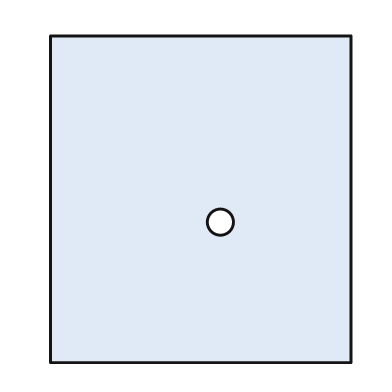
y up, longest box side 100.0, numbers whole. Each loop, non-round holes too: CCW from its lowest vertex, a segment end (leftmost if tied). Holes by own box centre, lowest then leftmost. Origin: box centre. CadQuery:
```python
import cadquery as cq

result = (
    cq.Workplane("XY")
    .moveTo(-46.0, -50.0)
    .lineTo(46.0, -50.0)
    .lineTo(46.0, 50.0)
    .lineTo(-46.0, 50.0)
    .close()
    .moveTo(6.0, -7.0)
    .circle(4.0)
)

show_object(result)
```